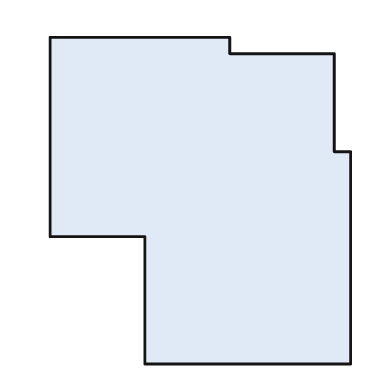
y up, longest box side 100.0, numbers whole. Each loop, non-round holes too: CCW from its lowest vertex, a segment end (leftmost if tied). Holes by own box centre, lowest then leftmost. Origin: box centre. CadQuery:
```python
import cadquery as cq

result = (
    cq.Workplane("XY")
    .moveTo(-17.0, -50.0)
    .lineTo(46.0, -50.0)
    .lineTo(46.0, 15.0)
    .lineTo(41.0, 15.0)
    .lineTo(41.0, 45.0)
    .lineTo(9.0, 45.0)
    .lineTo(9.0, 50.0)
    .lineTo(-46.0, 50.0)
    .lineTo(-46.0, -11.0)
    .lineTo(-17.0, -11.0)
    .close()
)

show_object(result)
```